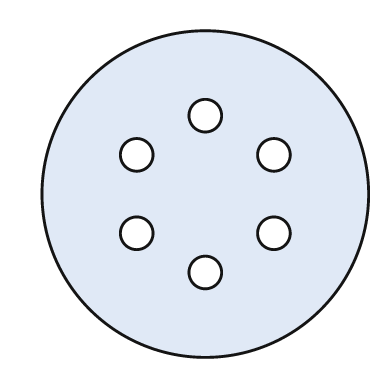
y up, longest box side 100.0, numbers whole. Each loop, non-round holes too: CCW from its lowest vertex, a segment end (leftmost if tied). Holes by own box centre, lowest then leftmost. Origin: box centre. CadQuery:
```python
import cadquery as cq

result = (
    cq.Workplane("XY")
    .moveTo(0.0, 0.0)
    .circle(50.0)
    .moveTo(0.0, -24.0)
    .circle(5.0)
    .moveTo(-21.0, -12.0)
    .circle(5.0)
    .moveTo(21.0, -12.0)
    .circle(5.0)
    .moveTo(-21.0, 12.0)
    .circle(5.0)
    .moveTo(21.0, 12.0)
    .circle(5.0)
    .moveTo(0.0, 24.0)
    .circle(5.0)
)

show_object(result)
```